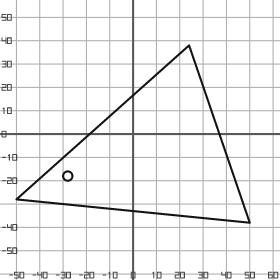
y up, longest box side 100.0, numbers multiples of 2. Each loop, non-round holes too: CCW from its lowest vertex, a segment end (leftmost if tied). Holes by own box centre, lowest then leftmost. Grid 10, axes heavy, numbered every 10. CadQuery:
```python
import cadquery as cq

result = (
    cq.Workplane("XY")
    .moveTo(50.0, -38.0)
    .lineTo(24.0, 38.0)
    .lineTo(-50.0, -28.0)
    .close()
    .moveTo(-28.0, -18.0)
    .circle(2.0)
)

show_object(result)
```